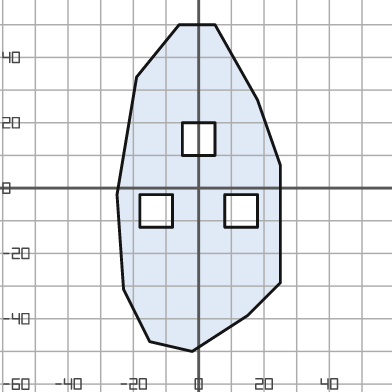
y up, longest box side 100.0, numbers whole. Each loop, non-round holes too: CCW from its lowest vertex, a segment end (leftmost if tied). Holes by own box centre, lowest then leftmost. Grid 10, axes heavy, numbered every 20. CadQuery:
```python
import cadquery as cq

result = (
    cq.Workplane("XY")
    .moveTo(-2.0, -50.0)
    .lineTo(15.0, -39.0)
    .lineTo(25.0, -29.0)
    .lineTo(25.0, 7.0)
    .lineTo(18.0, 27.0)
    .lineTo(5.0, 50.0)
    .lineTo(-6.0, 50.0)
    .lineTo(-19.0, 34.0)
    .lineTo(-25.0, -2.0)
    .lineTo(-23.0, -31.0)
    .lineTo(-15.0, -47.0)
    .close()
    .moveTo(-18.0, -12.0)
    .lineTo(-8.0, -12.0)
    .lineTo(-8.0, -2.0)
    .lineTo(-18.0, -2.0)
    .close()
    .moveTo(8.0, -12.0)
    .lineTo(18.0, -12.0)
    .lineTo(18.0, -2.0)
    .lineTo(8.0, -2.0)
    .close()
    .moveTo(-5.0, 10.0)
    .lineTo(5.0, 10.0)
    .lineTo(5.0, 20.0)
    .lineTo(-5.0, 20.0)
    .close()
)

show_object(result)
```